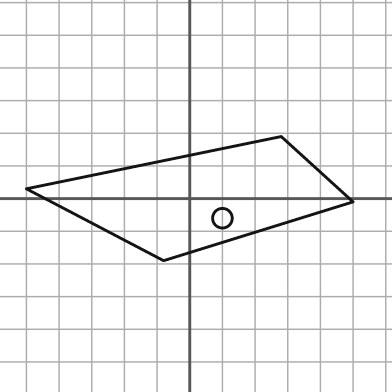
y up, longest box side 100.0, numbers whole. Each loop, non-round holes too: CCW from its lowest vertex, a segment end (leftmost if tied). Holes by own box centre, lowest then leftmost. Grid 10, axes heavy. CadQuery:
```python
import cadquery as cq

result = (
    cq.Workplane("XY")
    .moveTo(-8.0, -19.0)
    .lineTo(50.0, -1.0)
    .lineTo(28.0, 19.0)
    .lineTo(-50.0, 3.0)
    .close()
    .moveTo(10.0, -6.0)
    .circle(3.0)
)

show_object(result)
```